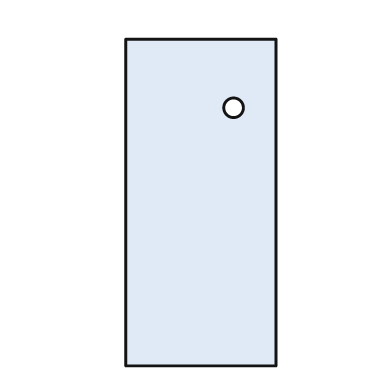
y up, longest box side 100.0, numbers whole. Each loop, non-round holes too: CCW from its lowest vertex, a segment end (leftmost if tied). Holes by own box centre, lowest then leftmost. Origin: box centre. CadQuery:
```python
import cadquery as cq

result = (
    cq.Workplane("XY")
    .moveTo(-23.0, -50.0)
    .lineTo(23.0, -50.0)
    .lineTo(23.0, 50.0)
    .lineTo(-23.0, 50.0)
    .close()
    .moveTo(10.0, 29.0)
    .circle(3.0)
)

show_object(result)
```